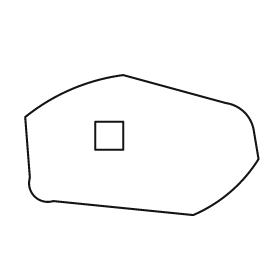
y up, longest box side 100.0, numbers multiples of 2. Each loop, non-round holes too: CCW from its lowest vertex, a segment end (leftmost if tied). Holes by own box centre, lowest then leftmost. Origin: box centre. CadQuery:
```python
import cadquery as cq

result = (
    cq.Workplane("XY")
    .moveTo(22.0, -30.0)
    .threePointArc((38.0, -20.0), (50.0, -6.0))
    .lineTo(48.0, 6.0)
    .threePointArc((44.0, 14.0), (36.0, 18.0))
    .lineTo(-8.0, 30.0)
    .threePointArc((-30.0, 24.0), (-50.0, 12.0))
    .lineTo(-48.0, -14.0)
    .threePointArc((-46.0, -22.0), (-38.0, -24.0))
    .close()
    .moveTo(-20.0, -2.0)
    .lineTo(-8.0, -2.0)
    .lineTo(-8.0, 10.0)
    .lineTo(-20.0, 10.0)
    .close()
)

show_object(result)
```